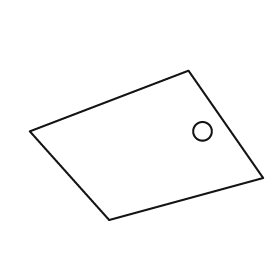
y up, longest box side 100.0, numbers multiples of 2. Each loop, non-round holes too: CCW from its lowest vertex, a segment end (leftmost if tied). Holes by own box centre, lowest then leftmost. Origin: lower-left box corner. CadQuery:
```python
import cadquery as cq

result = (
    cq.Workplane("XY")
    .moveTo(34.0, 0.0)
    .lineTo(100.0, 18.0)
    .lineTo(68.0, 64.0)
    .lineTo(0.0, 38.0)
    .close()
    .moveTo(74.0, 38.0)
    .circle(4.0)
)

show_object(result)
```